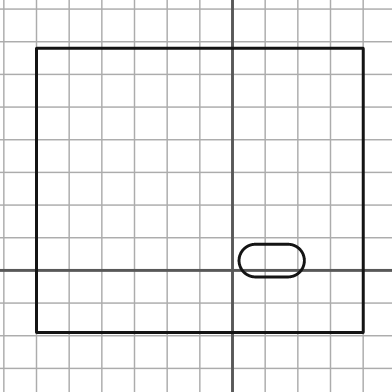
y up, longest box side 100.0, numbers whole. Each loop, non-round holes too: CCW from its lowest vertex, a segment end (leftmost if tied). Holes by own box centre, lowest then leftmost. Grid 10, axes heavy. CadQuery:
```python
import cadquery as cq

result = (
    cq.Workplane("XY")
    .moveTo(-60.0, -19.0)
    .lineTo(40.0, -19.0)
    .lineTo(40.0, 68.0)
    .lineTo(-60.0, 68.0)
    .close()
    .moveTo(7.0, -2.0)
    .lineTo(17.0, -2.0)
    .threePointArc((22.0, 3.0), (17.0, 8.0))
    .lineTo(7.0, 8.0)
    .threePointArc((2.0, 3.0), (7.0, -2.0))
    .close()
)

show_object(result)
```